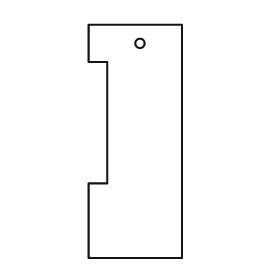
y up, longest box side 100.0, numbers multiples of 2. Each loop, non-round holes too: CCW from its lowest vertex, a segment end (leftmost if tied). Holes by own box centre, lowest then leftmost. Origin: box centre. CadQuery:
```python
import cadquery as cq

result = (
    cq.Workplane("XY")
    .moveTo(-20.0, -50.0)
    .lineTo(20.0, -50.0)
    .lineTo(20.0, 50.0)
    .lineTo(-20.0, 50.0)
    .lineTo(-20.0, 34.0)
    .lineTo(-12.0, 34.0)
    .lineTo(-12.0, -18.0)
    .lineTo(-20.0, -18.0)
    .close()
    .moveTo(2.0, 42.0)
    .circle(2.0)
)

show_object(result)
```